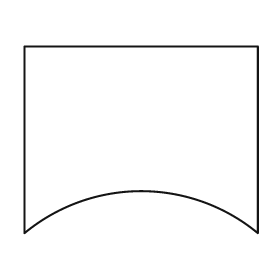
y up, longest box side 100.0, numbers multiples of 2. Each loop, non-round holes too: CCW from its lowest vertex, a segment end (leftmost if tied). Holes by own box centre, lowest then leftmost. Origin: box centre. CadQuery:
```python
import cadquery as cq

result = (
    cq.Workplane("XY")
    .moveTo(-50.0, -40.0)
    .threePointArc((0.0, -22.0), (50.0, -40.0))
    .lineTo(50.0, 40.0)
    .lineTo(-50.0, 40.0)
    .close()
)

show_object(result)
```